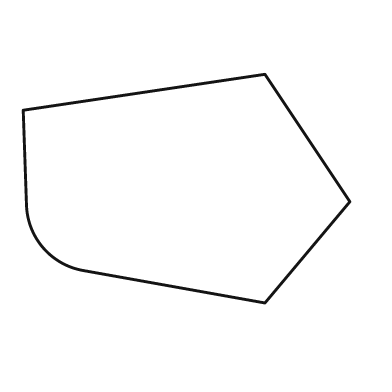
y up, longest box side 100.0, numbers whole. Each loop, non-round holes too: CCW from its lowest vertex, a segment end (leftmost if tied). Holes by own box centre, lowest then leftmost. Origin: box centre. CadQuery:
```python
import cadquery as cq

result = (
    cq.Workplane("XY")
    .moveTo(24.0, -35.0)
    .lineTo(50.0, -4.0)
    .lineTo(24.0, 35.0)
    .lineTo(-50.0, 24.0)
    .lineTo(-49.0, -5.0)
    .threePointArc((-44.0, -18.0), (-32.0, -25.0))
    .close()
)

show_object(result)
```